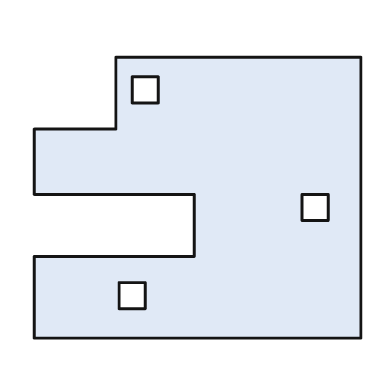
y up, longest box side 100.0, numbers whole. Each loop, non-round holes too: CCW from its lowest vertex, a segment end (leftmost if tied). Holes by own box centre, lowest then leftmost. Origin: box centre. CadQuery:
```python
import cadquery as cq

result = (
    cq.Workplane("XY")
    .moveTo(-50.0, -43.0)
    .lineTo(50.0, -43.0)
    .lineTo(50.0, 43.0)
    .lineTo(-25.0, 43.0)
    .lineTo(-25.0, 21.0)
    .lineTo(-50.0, 21.0)
    .lineTo(-50.0, 1.0)
    .lineTo(-1.0, 1.0)
    .lineTo(-1.0, -18.0)
    .lineTo(-50.0, -18.0)
    .close()
    .moveTo(-24.0, -34.0)
    .lineTo(-16.0, -34.0)
    .lineTo(-16.0, -26.0)
    .lineTo(-24.0, -26.0)
    .close()
    .moveTo(32.0, -7.0)
    .lineTo(40.0, -7.0)
    .lineTo(40.0, 1.0)
    .lineTo(32.0, 1.0)
    .close()
    .moveTo(-20.0, 29.0)
    .lineTo(-12.0, 29.0)
    .lineTo(-12.0, 37.0)
    .lineTo(-20.0, 37.0)
    .close()
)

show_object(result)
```